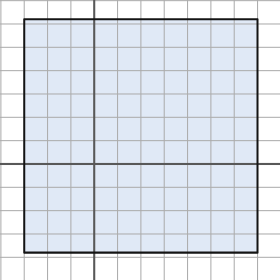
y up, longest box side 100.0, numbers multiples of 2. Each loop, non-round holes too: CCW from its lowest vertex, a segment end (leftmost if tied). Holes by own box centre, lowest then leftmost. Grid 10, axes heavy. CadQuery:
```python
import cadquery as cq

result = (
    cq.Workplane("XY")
    .moveTo(-30.0, -38.0)
    .lineTo(70.0, -38.0)
    .lineTo(70.0, 62.0)
    .lineTo(-30.0, 62.0)
    .close()
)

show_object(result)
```